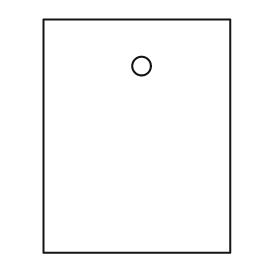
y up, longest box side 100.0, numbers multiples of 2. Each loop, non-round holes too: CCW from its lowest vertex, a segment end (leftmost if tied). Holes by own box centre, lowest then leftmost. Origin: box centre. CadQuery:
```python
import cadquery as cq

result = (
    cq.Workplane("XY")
    .moveTo(-40.0, -50.0)
    .lineTo(40.0, -50.0)
    .lineTo(40.0, 50.0)
    .lineTo(-40.0, 50.0)
    .close()
    .moveTo(2.0, 30.0)
    .circle(4.0)
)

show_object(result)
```